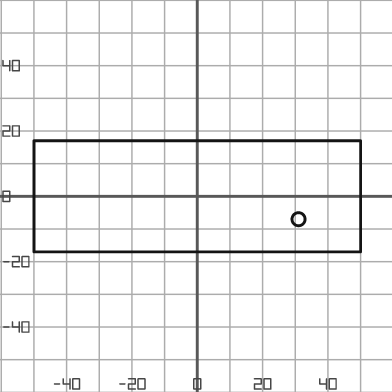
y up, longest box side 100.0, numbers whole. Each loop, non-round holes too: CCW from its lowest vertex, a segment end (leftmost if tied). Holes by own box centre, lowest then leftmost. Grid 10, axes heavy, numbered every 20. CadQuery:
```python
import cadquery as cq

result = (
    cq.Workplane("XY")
    .moveTo(-50.0, -17.0)
    .lineTo(50.0, -17.0)
    .lineTo(50.0, 17.0)
    .lineTo(-50.0, 17.0)
    .close()
    .moveTo(31.0, -7.0)
    .circle(2.0)
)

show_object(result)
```